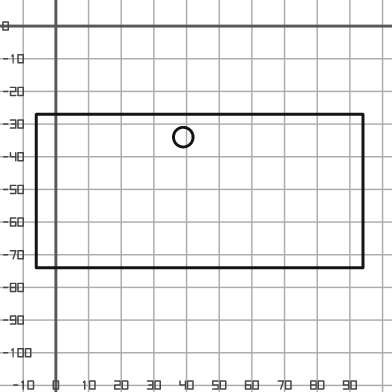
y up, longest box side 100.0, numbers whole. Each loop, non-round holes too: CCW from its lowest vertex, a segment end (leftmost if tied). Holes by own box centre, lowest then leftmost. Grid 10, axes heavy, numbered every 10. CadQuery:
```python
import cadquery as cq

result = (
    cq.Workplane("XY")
    .moveTo(-6.0, -74.0)
    .lineTo(94.0, -74.0)
    .lineTo(94.0, -27.0)
    .lineTo(-6.0, -27.0)
    .close()
    .moveTo(39.0, -34.0)
    .circle(3.0)
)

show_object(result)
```